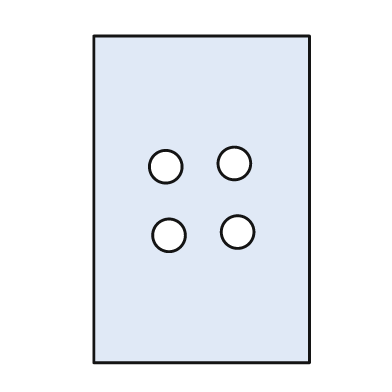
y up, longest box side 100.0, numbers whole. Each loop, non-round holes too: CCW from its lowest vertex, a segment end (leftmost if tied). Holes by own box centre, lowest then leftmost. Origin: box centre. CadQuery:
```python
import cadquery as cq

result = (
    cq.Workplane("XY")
    .moveTo(-33.0, -50.0)
    .lineTo(33.0, -50.0)
    .lineTo(33.0, 50.0)
    .lineTo(-33.0, 50.0)
    .close()
    .moveTo(-10.0, -11.0)
    .circle(5.0)
    .moveTo(11.0, -10.0)
    .circle(5.0)
    .moveTo(-11.0, 10.0)
    .circle(5.0)
    .moveTo(10.0, 11.0)
    .circle(5.0)
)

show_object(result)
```